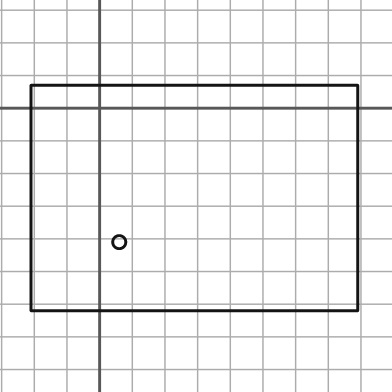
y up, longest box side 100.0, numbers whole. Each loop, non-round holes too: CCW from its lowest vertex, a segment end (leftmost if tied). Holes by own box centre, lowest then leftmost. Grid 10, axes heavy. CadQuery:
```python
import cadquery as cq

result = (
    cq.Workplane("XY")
    .moveTo(-21.0, -62.0)
    .lineTo(79.0, -62.0)
    .lineTo(79.0, 7.0)
    .lineTo(-21.0, 7.0)
    .close()
    .moveTo(6.0, -41.0)
    .circle(2.0)
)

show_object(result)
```